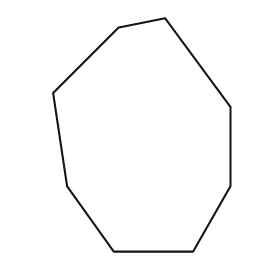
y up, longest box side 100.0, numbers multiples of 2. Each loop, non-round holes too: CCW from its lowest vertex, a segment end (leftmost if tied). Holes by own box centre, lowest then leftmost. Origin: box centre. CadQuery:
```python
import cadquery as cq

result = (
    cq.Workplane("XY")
    .moveTo(-12.0, -50.0)
    .lineTo(22.0, -50.0)
    .lineTo(38.0, -22.0)
    .lineTo(38.0, 12.0)
    .lineTo(10.0, 50.0)
    .lineTo(-10.0, 46.0)
    .lineTo(-38.0, 18.0)
    .lineTo(-32.0, -22.0)
    .close()
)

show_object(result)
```